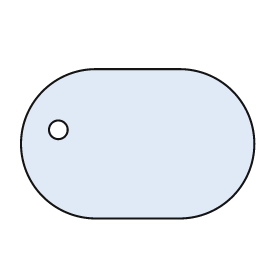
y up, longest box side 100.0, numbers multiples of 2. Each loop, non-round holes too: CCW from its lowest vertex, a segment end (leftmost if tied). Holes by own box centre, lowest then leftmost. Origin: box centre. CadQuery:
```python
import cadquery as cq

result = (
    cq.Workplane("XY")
    .moveTo(-18.0, -32.0)
    .lineTo(18.0, -32.0)
    .threePointArc((50.0, 0.0), (18.0, 32.0))
    .lineTo(-18.0, 32.0)
    .threePointArc((-50.0, 0.0), (-18.0, -32.0))
    .close()
    .moveTo(-34.0, 6.0)
    .circle(4.0)
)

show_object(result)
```